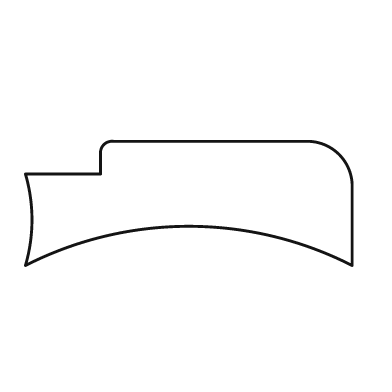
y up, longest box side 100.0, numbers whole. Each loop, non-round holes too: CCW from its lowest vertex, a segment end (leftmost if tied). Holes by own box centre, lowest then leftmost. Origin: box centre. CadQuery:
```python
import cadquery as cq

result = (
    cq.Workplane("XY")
    .moveTo(-50.0, -19.0)
    .threePointArc((0.0, -7.0), (50.0, -19.0))
    .lineTo(50.0, 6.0)
    .threePointArc((46.0, 15.0), (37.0, 19.0))
    .lineTo(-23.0, 19.0)
    .threePointArc((-26.0, 18.0), (-27.0, 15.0))
    .lineTo(-27.0, 9.0)
    .lineTo(-50.0, 9.0)
    .threePointArc((-48.0, -5.0), (-50.0, -19.0))
    .close()
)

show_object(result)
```